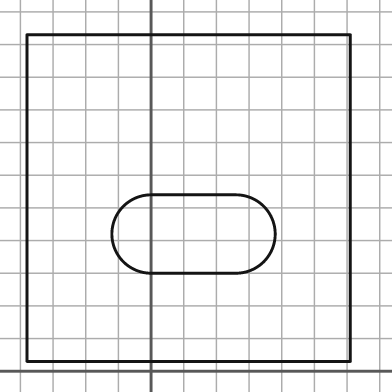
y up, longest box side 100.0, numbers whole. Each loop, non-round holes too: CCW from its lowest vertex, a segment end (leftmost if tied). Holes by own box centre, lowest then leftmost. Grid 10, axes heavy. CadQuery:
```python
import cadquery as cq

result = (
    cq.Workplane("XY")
    .moveTo(-38.0, 3.0)
    .lineTo(61.0, 3.0)
    .lineTo(61.0, 103.0)
    .lineTo(-38.0, 103.0)
    .close()
    .moveTo(0.0, 30.0)
    .lineTo(26.0, 30.0)
    .threePointArc((38.0, 42.0), (26.0, 54.0))
    .lineTo(0.0, 54.0)
    .threePointArc((-12.0, 42.0), (0.0, 30.0))
    .close()
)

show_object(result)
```